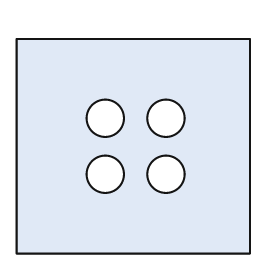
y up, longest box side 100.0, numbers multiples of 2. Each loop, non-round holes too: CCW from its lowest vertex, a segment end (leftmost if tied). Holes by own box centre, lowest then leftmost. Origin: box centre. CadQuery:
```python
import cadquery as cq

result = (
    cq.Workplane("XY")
    .moveTo(-50.0, -46.0)
    .lineTo(50.0, -46.0)
    .lineTo(50.0, 46.0)
    .lineTo(-50.0, 46.0)
    .close()
    .moveTo(-12.0, -12.0)
    .circle(8.0)
    .moveTo(14.0, -12.0)
    .circle(8.0)
    .moveTo(-12.0, 12.0)
    .circle(8.0)
    .moveTo(14.0, 12.0)
    .circle(8.0)
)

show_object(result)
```